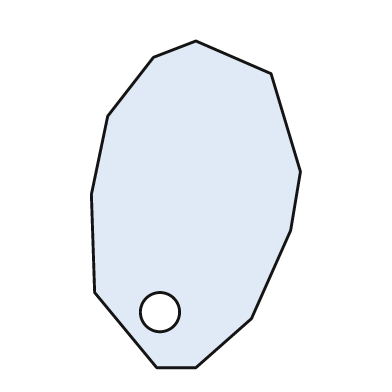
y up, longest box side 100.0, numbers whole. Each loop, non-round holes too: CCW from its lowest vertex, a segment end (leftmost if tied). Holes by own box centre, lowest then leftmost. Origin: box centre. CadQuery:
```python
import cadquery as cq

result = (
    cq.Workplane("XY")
    .moveTo(-12.0, -50.0)
    .lineTo(0.0, -50.0)
    .lineTo(17.0, -35.0)
    .lineTo(29.0, -8.0)
    .lineTo(32.0, 10.0)
    .lineTo(23.0, 40.0)
    .lineTo(0.0, 50.0)
    .lineTo(-13.0, 45.0)
    .lineTo(-27.0, 27.0)
    .lineTo(-32.0, 3.0)
    .lineTo(-31.0, -27.0)
    .close()
    .moveTo(-11.0, -33.0)
    .circle(6.0)
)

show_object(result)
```